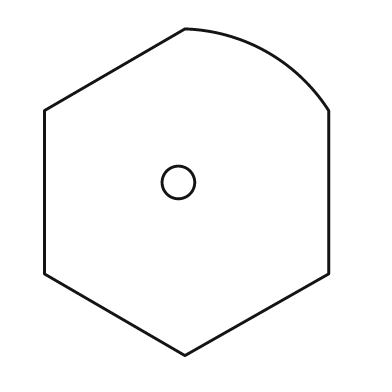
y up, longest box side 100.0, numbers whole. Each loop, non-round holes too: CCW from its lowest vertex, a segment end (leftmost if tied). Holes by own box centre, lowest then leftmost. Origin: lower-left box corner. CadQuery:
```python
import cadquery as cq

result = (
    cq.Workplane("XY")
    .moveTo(43.0, 0.0)
    .lineTo(87.0, 25.0)
    .lineTo(87.0, 75.0)
    .threePointArc((68.0, 93.0), (43.0, 100.0))
    .lineTo(0.0, 75.0)
    .lineTo(0.0, 25.0)
    .close()
    .moveTo(41.0, 53.0)
    .circle(5.0)
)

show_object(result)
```